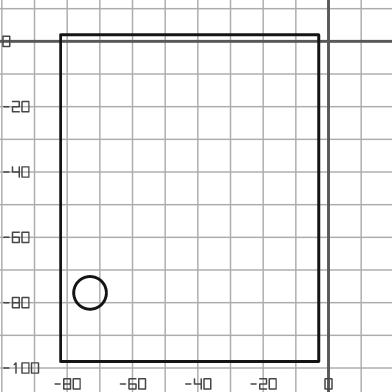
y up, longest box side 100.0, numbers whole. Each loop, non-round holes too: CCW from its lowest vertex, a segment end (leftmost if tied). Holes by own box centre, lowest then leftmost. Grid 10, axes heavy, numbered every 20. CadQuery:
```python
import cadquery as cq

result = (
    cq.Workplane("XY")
    .moveTo(-82.0, -98.0)
    .lineTo(-3.0, -98.0)
    .lineTo(-3.0, 2.0)
    .lineTo(-82.0, 2.0)
    .close()
    .moveTo(-73.0, -77.0)
    .circle(5.0)
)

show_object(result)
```